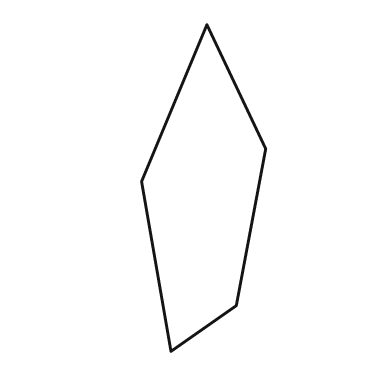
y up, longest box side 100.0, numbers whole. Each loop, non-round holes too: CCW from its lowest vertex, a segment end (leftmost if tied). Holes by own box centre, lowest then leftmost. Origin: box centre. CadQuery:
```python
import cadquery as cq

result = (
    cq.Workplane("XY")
    .moveTo(-10.0, -50.0)
    .lineTo(10.0, -36.0)
    .lineTo(19.0, 12.0)
    .lineTo(1.0, 50.0)
    .lineTo(-19.0, 2.0)
    .close()
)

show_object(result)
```